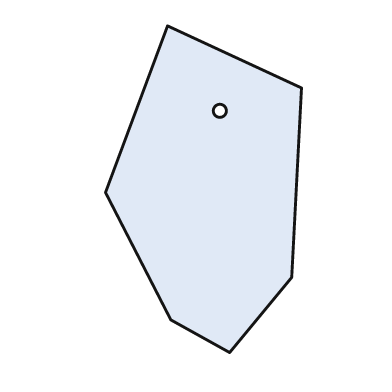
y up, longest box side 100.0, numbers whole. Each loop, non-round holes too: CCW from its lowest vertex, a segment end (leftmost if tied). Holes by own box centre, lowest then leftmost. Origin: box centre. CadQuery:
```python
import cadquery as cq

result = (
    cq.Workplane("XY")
    .moveTo(8.0, -50.0)
    .lineTo(27.0, -27.0)
    .lineTo(30.0, 31.0)
    .lineTo(-11.0, 50.0)
    .lineTo(-30.0, -1.0)
    .lineTo(-10.0, -40.0)
    .close()
    .moveTo(5.0, 24.0)
    .circle(2.0)
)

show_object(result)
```